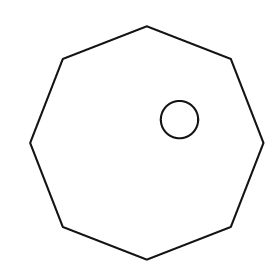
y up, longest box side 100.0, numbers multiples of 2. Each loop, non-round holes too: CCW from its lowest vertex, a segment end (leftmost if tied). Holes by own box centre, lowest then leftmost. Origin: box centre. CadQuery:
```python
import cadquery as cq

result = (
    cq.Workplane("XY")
    .moveTo(0.0, -50.0)
    .lineTo(36.0, -36.0)
    .lineTo(50.0, 0.0)
    .lineTo(36.0, 36.0)
    .lineTo(0.0, 50.0)
    .lineTo(-36.0, 36.0)
    .lineTo(-50.0, 0.0)
    .lineTo(-36.0, -36.0)
    .close()
    .moveTo(14.0, 10.0)
    .circle(8.0)
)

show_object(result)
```